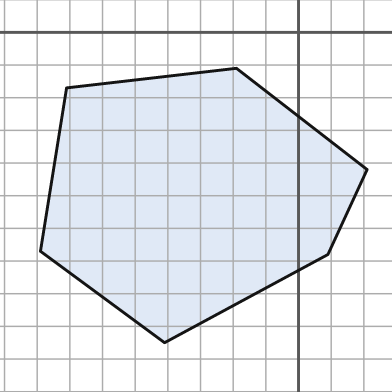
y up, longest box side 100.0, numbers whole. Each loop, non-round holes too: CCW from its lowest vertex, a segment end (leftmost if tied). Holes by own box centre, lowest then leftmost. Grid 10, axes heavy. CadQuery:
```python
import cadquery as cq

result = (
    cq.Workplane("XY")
    .moveTo(-41.0, -95.0)
    .lineTo(9.0, -68.0)
    .lineTo(21.0, -42.0)
    .lineTo(-19.0, -11.0)
    .lineTo(-71.0, -17.0)
    .lineTo(-79.0, -67.0)
    .close()
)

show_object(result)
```